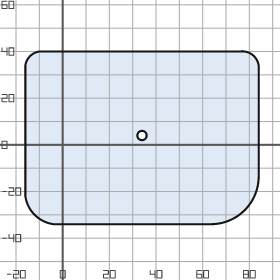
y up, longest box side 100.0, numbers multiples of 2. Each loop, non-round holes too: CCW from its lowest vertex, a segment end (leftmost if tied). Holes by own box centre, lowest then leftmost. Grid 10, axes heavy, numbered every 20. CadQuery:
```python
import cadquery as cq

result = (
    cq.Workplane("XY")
    .moveTo(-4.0, -34.0)
    .lineTo(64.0, -34.0)
    .threePointArc((78.0, -28.0), (84.0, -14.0))
    .lineTo(84.0, 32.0)
    .threePointArc((82.0, 38.0), (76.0, 40.0))
    .lineTo(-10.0, 40.0)
    .threePointArc((-14.0, 38.0), (-16.0, 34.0))
    .lineTo(-16.0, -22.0)
    .threePointArc((-12.0, -30.0), (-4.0, -34.0))
    .close()
    .moveTo(34.0, 4.0)
    .circle(2.0)
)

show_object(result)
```